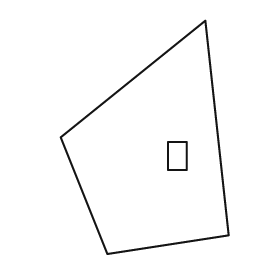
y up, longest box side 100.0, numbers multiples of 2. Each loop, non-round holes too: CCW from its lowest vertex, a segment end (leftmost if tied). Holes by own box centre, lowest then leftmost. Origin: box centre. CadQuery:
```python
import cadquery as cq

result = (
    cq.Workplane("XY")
    .moveTo(-16.0, -50.0)
    .lineTo(36.0, -42.0)
    .lineTo(26.0, 50.0)
    .lineTo(-36.0, 0.0)
    .close()
    .moveTo(10.0, -14.0)
    .lineTo(18.0, -14.0)
    .lineTo(18.0, -2.0)
    .lineTo(10.0, -2.0)
    .close()
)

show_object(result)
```